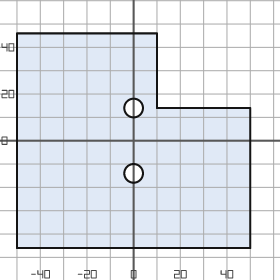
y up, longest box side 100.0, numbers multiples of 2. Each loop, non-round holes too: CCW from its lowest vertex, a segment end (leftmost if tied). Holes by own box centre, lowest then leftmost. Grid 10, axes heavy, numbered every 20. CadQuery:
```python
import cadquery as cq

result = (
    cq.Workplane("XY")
    .moveTo(-50.0, -46.0)
    .lineTo(50.0, -46.0)
    .lineTo(50.0, 14.0)
    .lineTo(10.0, 14.0)
    .lineTo(10.0, 46.0)
    .lineTo(-50.0, 46.0)
    .close()
    .moveTo(0.0, -14.0)
    .circle(4.0)
    .moveTo(0.0, 14.0)
    .circle(4.0)
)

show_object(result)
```